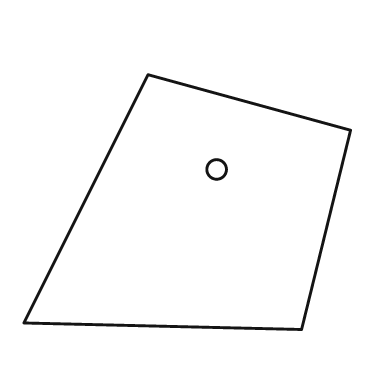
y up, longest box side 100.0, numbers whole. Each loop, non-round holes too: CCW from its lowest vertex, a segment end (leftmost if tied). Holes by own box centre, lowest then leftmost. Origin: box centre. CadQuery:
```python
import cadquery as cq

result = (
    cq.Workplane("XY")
    .moveTo(35.0, -39.0)
    .lineTo(50.0, 22.0)
    .lineTo(-12.0, 39.0)
    .lineTo(-50.0, -37.0)
    .close()
    .moveTo(9.0, 10.0)
    .circle(3.0)
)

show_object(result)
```